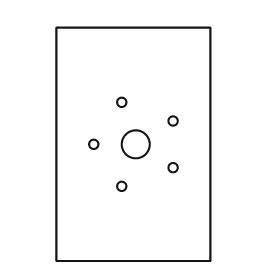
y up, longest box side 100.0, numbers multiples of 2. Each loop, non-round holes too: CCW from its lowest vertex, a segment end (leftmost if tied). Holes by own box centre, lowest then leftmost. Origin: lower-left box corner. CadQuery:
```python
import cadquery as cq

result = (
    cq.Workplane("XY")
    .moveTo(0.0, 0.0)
    .lineTo(66.0, 0.0)
    .lineTo(66.0, 100.0)
    .lineTo(0.0, 100.0)
    .close()
    .moveTo(28.0, 32.0)
    .circle(2.0)
    .moveTo(50.0, 40.0)
    .circle(2.0)
    .moveTo(16.0, 50.0)
    .circle(2.0)
    .moveTo(34.0, 50.0)
    .circle(6.0)
    .moveTo(50.0, 60.0)
    .circle(2.0)
    .moveTo(28.0, 68.0)
    .circle(2.0)
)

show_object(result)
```